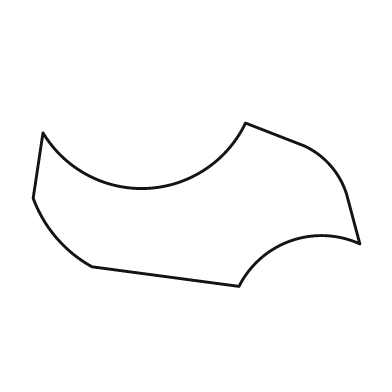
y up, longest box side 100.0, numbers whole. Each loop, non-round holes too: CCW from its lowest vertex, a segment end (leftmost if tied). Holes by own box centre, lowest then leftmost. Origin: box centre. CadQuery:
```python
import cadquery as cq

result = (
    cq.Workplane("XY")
    .moveTo(13.0, -25.0)
    .threePointArc((29.0, -11.0), (50.0, -12.0))
    .lineTo(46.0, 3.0)
    .threePointArc((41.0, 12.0), (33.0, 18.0))
    .lineTo(15.0, 25.0)
    .threePointArc((-15.0, 5.0), (-47.0, 22.0))
    .lineTo(-50.0, 2.0)
    .threePointArc((-43.0, -10.0), (-32.0, -19.0))
    .close()
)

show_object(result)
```